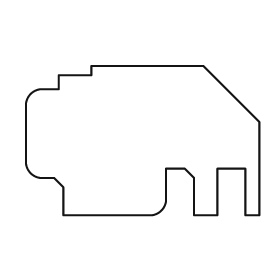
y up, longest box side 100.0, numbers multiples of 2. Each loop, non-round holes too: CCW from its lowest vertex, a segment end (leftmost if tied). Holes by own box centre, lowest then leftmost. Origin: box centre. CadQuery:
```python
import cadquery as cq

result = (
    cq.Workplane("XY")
    .moveTo(-34.0, -32.0)
    .lineTo(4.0, -32.0)
    .threePointArc((8.0, -30.0), (10.0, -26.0))
    .lineTo(10.0, -12.0)
    .lineTo(18.0, -12.0)
    .lineTo(22.0, -16.0)
    .lineTo(22.0, -32.0)
    .lineTo(32.0, -32.0)
    .lineTo(32.0, -12.0)
    .lineTo(44.0, -12.0)
    .lineTo(44.0, -32.0)
    .lineTo(50.0, -32.0)
    .lineTo(50.0, 8.0)
    .lineTo(26.0, 32.0)
    .lineTo(-22.0, 32.0)
    .lineTo(-22.0, 28.0)
    .lineTo(-36.0, 28.0)
    .lineTo(-36.0, 22.0)
    .lineTo(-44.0, 22.0)
    .threePointArc((-48.0, 20.0), (-50.0, 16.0))
    .lineTo(-50.0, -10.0)
    .threePointArc((-48.0, -14.0), (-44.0, -16.0))
    .lineTo(-38.0, -16.0)
    .lineTo(-34.0, -20.0)
    .close()
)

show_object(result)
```